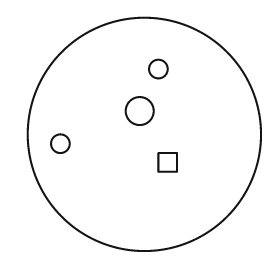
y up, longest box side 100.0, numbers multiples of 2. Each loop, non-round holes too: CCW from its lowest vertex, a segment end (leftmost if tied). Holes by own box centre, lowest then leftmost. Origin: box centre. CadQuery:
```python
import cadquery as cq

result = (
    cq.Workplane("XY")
    .moveTo(0.0, 0.0)
    .circle(50.0)
    .moveTo(6.0, -16.0)
    .lineTo(14.0, -16.0)
    .lineTo(14.0, -8.0)
    .lineTo(6.0, -8.0)
    .close()
    .moveTo(-36.0, -4.0)
    .circle(4.0)
    .moveTo(-2.0, 10.0)
    .circle(6.0)
    .moveTo(6.0, 28.0)
    .circle(4.0)
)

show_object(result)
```